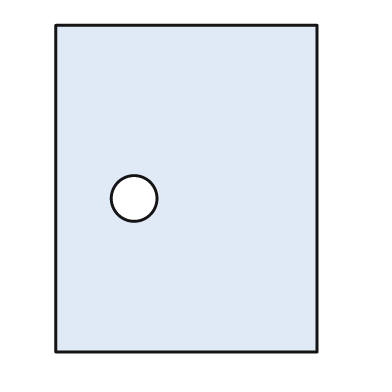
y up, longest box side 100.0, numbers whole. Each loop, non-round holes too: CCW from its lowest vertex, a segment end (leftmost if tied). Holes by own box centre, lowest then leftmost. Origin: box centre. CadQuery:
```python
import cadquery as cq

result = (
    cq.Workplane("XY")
    .moveTo(-40.0, -50.0)
    .lineTo(40.0, -50.0)
    .lineTo(40.0, 50.0)
    .lineTo(-40.0, 50.0)
    .close()
    .moveTo(-16.0, -3.0)
    .circle(7.0)
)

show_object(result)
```